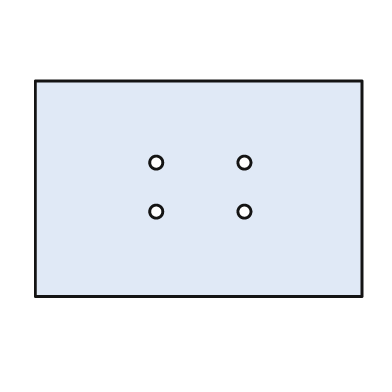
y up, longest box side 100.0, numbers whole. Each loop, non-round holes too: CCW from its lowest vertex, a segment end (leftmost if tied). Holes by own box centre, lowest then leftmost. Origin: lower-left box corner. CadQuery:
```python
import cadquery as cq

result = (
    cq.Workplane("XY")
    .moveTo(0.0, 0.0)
    .lineTo(100.0, 0.0)
    .lineTo(100.0, 66.0)
    .lineTo(0.0, 66.0)
    .close()
    .moveTo(37.0, 26.0)
    .circle(2.0)
    .moveTo(64.0, 26.0)
    .circle(2.0)
    .moveTo(37.0, 41.0)
    .circle(2.0)
    .moveTo(64.0, 41.0)
    .circle(2.0)
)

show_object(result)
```